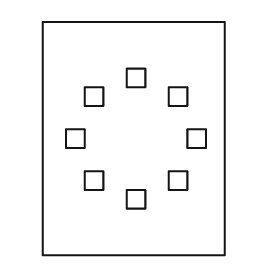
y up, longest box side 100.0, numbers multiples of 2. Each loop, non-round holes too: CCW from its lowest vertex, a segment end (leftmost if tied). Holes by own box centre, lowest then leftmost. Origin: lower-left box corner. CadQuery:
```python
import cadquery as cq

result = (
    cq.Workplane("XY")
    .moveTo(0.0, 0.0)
    .lineTo(78.0, 0.0)
    .lineTo(78.0, 100.0)
    .lineTo(0.0, 100.0)
    .close()
    .moveTo(36.0, 20.0)
    .lineTo(44.0, 20.0)
    .lineTo(44.0, 28.0)
    .lineTo(36.0, 28.0)
    .close()
    .moveTo(18.0, 28.0)
    .lineTo(26.0, 28.0)
    .lineTo(26.0, 36.0)
    .lineTo(18.0, 36.0)
    .close()
    .moveTo(54.0, 28.0)
    .lineTo(62.0, 28.0)
    .lineTo(62.0, 36.0)
    .lineTo(54.0, 36.0)
    .close()
    .moveTo(10.0, 46.0)
    .lineTo(18.0, 46.0)
    .lineTo(18.0, 54.0)
    .lineTo(10.0, 54.0)
    .close()
    .moveTo(62.0, 46.0)
    .lineTo(70.0, 46.0)
    .lineTo(70.0, 54.0)
    .lineTo(62.0, 54.0)
    .close()
    .moveTo(18.0, 64.0)
    .lineTo(26.0, 64.0)
    .lineTo(26.0, 72.0)
    .lineTo(18.0, 72.0)
    .close()
    .moveTo(54.0, 64.0)
    .lineTo(62.0, 64.0)
    .lineTo(62.0, 72.0)
    .lineTo(54.0, 72.0)
    .close()
    .moveTo(36.0, 72.0)
    .lineTo(44.0, 72.0)
    .lineTo(44.0, 80.0)
    .lineTo(36.0, 80.0)
    .close()
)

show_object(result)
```